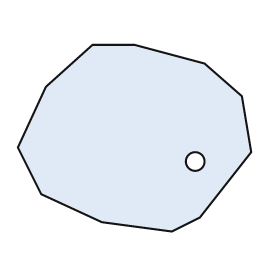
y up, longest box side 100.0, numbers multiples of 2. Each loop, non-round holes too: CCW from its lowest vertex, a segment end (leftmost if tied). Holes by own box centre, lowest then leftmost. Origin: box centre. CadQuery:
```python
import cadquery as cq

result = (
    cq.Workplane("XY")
    .moveTo(16.0, -40.0)
    .lineTo(28.0, -34.0)
    .lineTo(50.0, -6.0)
    .lineTo(46.0, 18.0)
    .lineTo(30.0, 32.0)
    .lineTo(0.0, 40.0)
    .lineTo(-18.0, 40.0)
    .lineTo(-38.0, 22.0)
    .lineTo(-50.0, -4.0)
    .lineTo(-40.0, -24.0)
    .lineTo(-14.0, -36.0)
    .close()
    .moveTo(26.0, -10.0)
    .circle(4.0)
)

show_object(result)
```